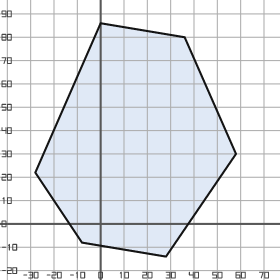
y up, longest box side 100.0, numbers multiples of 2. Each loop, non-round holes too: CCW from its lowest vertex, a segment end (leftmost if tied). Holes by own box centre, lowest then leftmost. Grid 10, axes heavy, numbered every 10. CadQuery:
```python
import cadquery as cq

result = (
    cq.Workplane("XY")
    .moveTo(28.0, -14.0)
    .lineTo(58.0, 30.0)
    .lineTo(36.0, 80.0)
    .lineTo(0.0, 86.0)
    .lineTo(-28.0, 22.0)
    .lineTo(-8.0, -8.0)
    .close()
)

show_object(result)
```